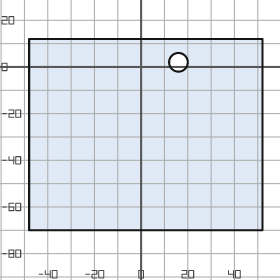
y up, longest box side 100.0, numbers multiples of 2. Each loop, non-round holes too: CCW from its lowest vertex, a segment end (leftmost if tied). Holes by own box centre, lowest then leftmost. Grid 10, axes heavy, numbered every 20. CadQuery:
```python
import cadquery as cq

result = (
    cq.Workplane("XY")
    .moveTo(-48.0, -70.0)
    .lineTo(52.0, -70.0)
    .lineTo(52.0, 12.0)
    .lineTo(-48.0, 12.0)
    .close()
    .moveTo(16.0, 2.0)
    .circle(4.0)
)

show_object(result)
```